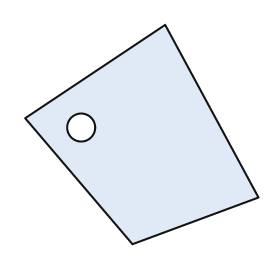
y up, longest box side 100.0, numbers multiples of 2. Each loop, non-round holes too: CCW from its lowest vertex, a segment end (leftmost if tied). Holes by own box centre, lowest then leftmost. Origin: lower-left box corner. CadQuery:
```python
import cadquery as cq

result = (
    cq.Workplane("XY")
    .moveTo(46.0, 0.0)
    .lineTo(100.0, 20.0)
    .lineTo(60.0, 94.0)
    .lineTo(0.0, 54.0)
    .close()
    .moveTo(24.0, 50.0)
    .circle(6.0)
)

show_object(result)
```